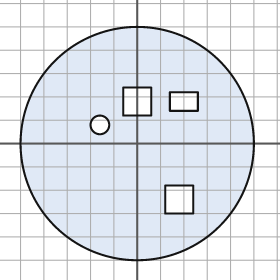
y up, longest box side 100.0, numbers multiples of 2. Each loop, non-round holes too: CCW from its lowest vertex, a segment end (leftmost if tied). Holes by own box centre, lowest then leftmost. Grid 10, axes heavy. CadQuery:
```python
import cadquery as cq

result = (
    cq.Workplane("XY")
    .moveTo(0.0, 0.0)
    .circle(50.0)
    .moveTo(12.0, -30.0)
    .lineTo(24.0, -30.0)
    .lineTo(24.0, -18.0)
    .lineTo(12.0, -18.0)
    .close()
    .moveTo(-16.0, 8.0)
    .circle(4.0)
    .moveTo(-6.0, 12.0)
    .lineTo(6.0, 12.0)
    .lineTo(6.0, 24.0)
    .lineTo(-6.0, 24.0)
    .close()
    .moveTo(14.0, 14.0)
    .lineTo(26.0, 14.0)
    .lineTo(26.0, 22.0)
    .lineTo(14.0, 22.0)
    .close()
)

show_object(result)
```